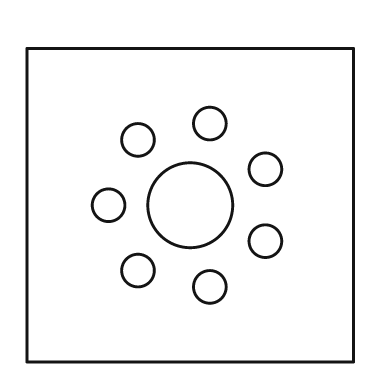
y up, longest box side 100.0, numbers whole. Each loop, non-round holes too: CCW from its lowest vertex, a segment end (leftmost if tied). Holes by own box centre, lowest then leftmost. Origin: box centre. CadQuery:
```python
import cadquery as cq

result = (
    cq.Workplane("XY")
    .moveTo(-50.0, -48.0)
    .lineTo(50.0, -48.0)
    .lineTo(50.0, 48.0)
    .lineTo(-50.0, 48.0)
    .close()
    .moveTo(6.0, -25.0)
    .circle(5.0)
    .moveTo(-16.0, -20.0)
    .circle(5.0)
    .moveTo(23.0, -11.0)
    .circle(5.0)
    .moveTo(-25.0, 0.0)
    .circle(5.0)
    .moveTo(0.0, 0.0)
    .circle(13.0)
    .moveTo(23.0, 11.0)
    .circle(5.0)
    .moveTo(-16.0, 20.0)
    .circle(5.0)
    .moveTo(6.0, 25.0)
    .circle(5.0)
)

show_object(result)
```